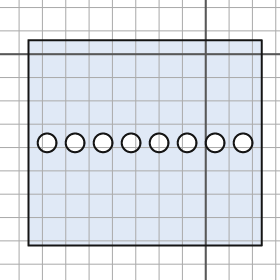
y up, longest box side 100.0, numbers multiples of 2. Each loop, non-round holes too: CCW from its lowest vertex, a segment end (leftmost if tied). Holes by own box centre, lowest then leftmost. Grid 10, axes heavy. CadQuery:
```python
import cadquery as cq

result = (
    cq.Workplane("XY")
    .moveTo(-76.0, -82.0)
    .lineTo(24.0, -82.0)
    .lineTo(24.0, 6.0)
    .lineTo(-76.0, 6.0)
    .close()
    .moveTo(-68.0, -38.0)
    .circle(4.0)
    .moveTo(-56.0, -38.0)
    .circle(4.0)
    .moveTo(-44.0, -38.0)
    .circle(4.0)
    .moveTo(-32.0, -38.0)
    .circle(4.0)
    .moveTo(-20.0, -38.0)
    .circle(4.0)
    .moveTo(-8.0, -38.0)
    .circle(4.0)
    .moveTo(4.0, -38.0)
    .circle(4.0)
    .moveTo(16.0, -38.0)
    .circle(4.0)
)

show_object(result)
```